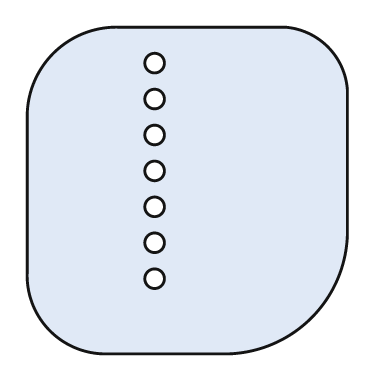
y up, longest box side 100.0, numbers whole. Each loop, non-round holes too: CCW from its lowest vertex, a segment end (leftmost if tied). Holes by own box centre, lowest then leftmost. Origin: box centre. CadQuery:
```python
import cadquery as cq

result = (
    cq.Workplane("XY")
    .moveTo(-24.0, -50.0)
    .lineTo(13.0, -50.0)
    .threePointArc((38.0, -39.0), (49.0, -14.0))
    .lineTo(49.0, 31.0)
    .threePointArc((43.0, 44.0), (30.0, 50.0))
    .lineTo(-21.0, 50.0)
    .threePointArc((-41.0, 42.0), (-49.0, 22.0))
    .lineTo(-49.0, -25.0)
    .threePointArc((-42.0, -43.0), (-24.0, -50.0))
    .close()
    .moveTo(-10.0, -27.0)
    .circle(3.0)
    .moveTo(-10.0, -16.0)
    .circle(3.0)
    .moveTo(-10.0, -5.0)
    .circle(3.0)
    .moveTo(-10.0, 6.0)
    .circle(3.0)
    .moveTo(-10.0, 17.0)
    .circle(3.0)
    .moveTo(-10.0, 28.0)
    .circle(3.0)
    .moveTo(-10.0, 39.0)
    .circle(3.0)
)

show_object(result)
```